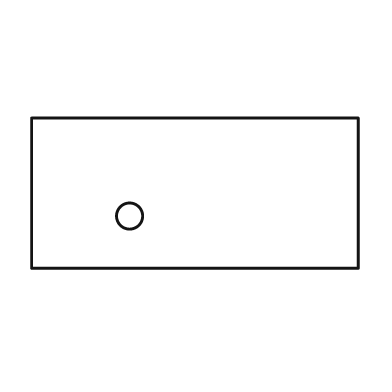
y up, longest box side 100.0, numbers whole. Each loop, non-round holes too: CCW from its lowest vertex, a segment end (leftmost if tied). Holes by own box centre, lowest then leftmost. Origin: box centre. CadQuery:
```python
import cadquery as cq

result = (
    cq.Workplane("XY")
    .moveTo(-50.0, -23.0)
    .lineTo(50.0, -23.0)
    .lineTo(50.0, 23.0)
    .lineTo(-50.0, 23.0)
    .close()
    .moveTo(-20.0, -7.0)
    .circle(4.0)
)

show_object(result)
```